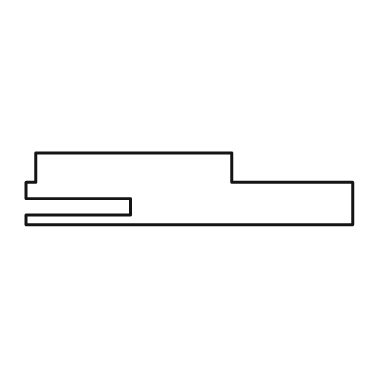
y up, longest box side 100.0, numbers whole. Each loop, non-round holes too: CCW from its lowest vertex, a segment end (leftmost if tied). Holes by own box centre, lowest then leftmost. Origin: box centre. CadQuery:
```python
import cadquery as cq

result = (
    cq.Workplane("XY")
    .moveTo(-50.0, -11.0)
    .lineTo(50.0, -11.0)
    .lineTo(50.0, 2.0)
    .lineTo(13.0, 2.0)
    .lineTo(13.0, 11.0)
    .lineTo(-47.0, 11.0)
    .lineTo(-47.0, 2.0)
    .lineTo(-50.0, 2.0)
    .lineTo(-50.0, -3.0)
    .lineTo(-18.0, -3.0)
    .lineTo(-18.0, -8.0)
    .lineTo(-50.0, -8.0)
    .close()
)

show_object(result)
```